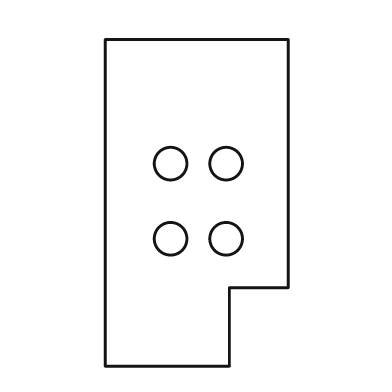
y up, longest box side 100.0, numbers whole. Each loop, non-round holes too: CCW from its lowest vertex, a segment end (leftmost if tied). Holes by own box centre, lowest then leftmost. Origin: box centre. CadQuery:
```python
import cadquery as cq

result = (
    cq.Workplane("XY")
    .moveTo(-28.0, -50.0)
    .lineTo(10.0, -50.0)
    .lineTo(10.0, -26.0)
    .lineTo(28.0, -26.0)
    .lineTo(28.0, 50.0)
    .lineTo(-28.0, 50.0)
    .close()
    .moveTo(-8.0, -11.0)
    .circle(5.0)
    .moveTo(9.0, -11.0)
    .circle(5.0)
    .moveTo(-8.0, 12.0)
    .circle(5.0)
    .moveTo(9.0, 12.0)
    .circle(5.0)
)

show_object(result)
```